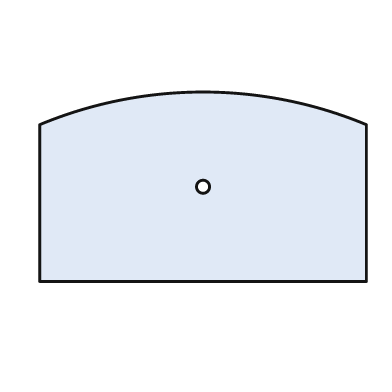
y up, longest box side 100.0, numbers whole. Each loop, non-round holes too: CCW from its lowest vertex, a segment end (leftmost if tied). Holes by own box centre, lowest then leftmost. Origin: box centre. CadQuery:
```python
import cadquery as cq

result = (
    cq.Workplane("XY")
    .moveTo(-50.0, -29.0)
    .lineTo(50.0, -29.0)
    .lineTo(50.0, 19.0)
    .threePointArc((0.0, 29.0), (-50.0, 19.0))
    .close()
    .moveTo(0.0, 0.0)
    .circle(2.0)
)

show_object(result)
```